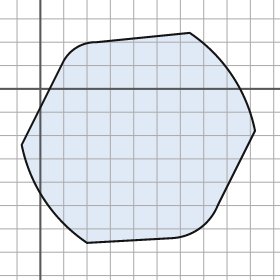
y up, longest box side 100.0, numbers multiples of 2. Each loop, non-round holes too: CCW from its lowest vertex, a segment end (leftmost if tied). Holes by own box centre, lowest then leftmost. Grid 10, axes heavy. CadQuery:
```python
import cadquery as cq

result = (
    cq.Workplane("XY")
    .moveTo(20.0, -66.0)
    .lineTo(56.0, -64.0)
    .threePointArc((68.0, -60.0), (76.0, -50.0))
    .lineTo(92.0, -18.0)
    .threePointArc((82.0, 6.0), (64.0, 24.0))
    .lineTo(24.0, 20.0)
    .threePointArc((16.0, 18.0), (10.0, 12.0))
    .lineTo(-8.0, -24.0)
    .threePointArc((2.0, -48.0), (20.0, -66.0))
    .close()
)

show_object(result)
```